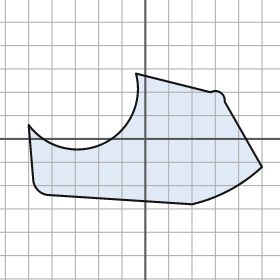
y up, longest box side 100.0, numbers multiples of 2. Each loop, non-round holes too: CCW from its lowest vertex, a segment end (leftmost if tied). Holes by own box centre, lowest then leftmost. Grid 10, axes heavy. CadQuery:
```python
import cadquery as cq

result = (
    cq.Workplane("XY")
    .moveTo(20.0, -28.0)
    .threePointArc((36.0, -22.0), (50.0, -12.0))
    .lineTo(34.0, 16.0)
    .threePointArc((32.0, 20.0), (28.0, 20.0))
    .lineTo(-4.0, 28.0)
    .threePointArc((-18.0, -2.0), (-50.0, 6.0))
    .lineTo(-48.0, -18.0)
    .threePointArc((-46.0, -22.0), (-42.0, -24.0))
    .close()
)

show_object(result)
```